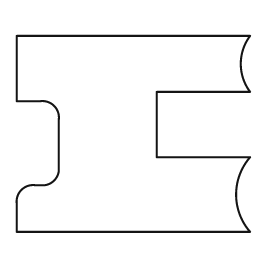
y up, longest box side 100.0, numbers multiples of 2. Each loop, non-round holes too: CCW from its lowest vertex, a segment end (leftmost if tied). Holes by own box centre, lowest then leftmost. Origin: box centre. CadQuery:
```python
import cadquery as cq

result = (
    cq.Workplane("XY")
    .moveTo(-50.0, -42.0)
    .lineTo(50.0, -42.0)
    .threePointArc((44.0, -26.0), (50.0, -10.0))
    .lineTo(10.0, -10.0)
    .lineTo(10.0, 18.0)
    .lineTo(50.0, 18.0)
    .threePointArc((46.0, 30.0), (50.0, 42.0))
    .lineTo(-50.0, 42.0)
    .lineTo(-50.0, 14.0)
    .lineTo(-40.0, 14.0)
    .threePointArc((-34.0, 12.0), (-32.0, 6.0))
    .lineTo(-32.0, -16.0)
    .threePointArc((-34.0, -20.0), (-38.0, -22.0))
    .lineTo(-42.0, -22.0)
    .threePointArc((-48.0, -24.0), (-50.0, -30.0))
    .close()
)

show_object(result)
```